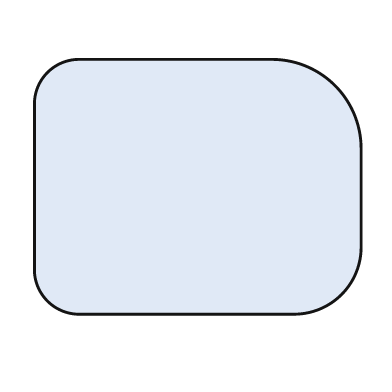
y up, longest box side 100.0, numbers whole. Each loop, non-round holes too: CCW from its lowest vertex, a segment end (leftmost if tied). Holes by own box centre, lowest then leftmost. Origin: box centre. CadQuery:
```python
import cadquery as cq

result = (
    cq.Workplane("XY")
    .moveTo(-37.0, -39.0)
    .lineTo(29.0, -39.0)
    .threePointArc((44.0, -33.0), (50.0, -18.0))
    .lineTo(50.0, 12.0)
    .threePointArc((42.0, 31.0), (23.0, 39.0))
    .lineTo(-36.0, 39.0)
    .threePointArc((-46.0, 35.0), (-50.0, 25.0))
    .lineTo(-50.0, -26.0)
    .threePointArc((-46.0, -35.0), (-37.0, -39.0))
    .close()
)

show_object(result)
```